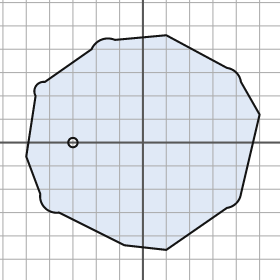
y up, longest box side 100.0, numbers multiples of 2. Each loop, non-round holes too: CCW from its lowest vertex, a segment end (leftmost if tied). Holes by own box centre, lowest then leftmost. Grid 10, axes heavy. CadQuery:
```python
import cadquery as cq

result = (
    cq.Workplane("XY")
    .moveTo(10.0, -46.0)
    .lineTo(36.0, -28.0)
    .threePointArc((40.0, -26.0), (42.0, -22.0))
    .lineTo(50.0, 12.0)
    .lineTo(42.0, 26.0)
    .threePointArc((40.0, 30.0), (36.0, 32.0))
    .lineTo(10.0, 46.0)
    .lineTo(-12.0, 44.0)
    .threePointArc((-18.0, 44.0), (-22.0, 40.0))
    .lineTo(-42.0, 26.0)
    .threePointArc((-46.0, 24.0), (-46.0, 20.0))
    .lineTo(-50.0, -6.0)
    .lineTo(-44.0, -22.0)
    .threePointArc((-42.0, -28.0), (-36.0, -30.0))
    .lineTo(-8.0, -44.0)
    .close()
    .moveTo(-30.0, 0.0)
    .circle(2.0)
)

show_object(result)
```